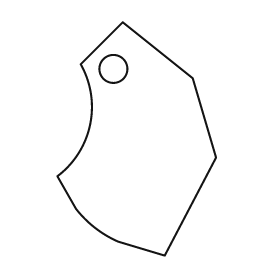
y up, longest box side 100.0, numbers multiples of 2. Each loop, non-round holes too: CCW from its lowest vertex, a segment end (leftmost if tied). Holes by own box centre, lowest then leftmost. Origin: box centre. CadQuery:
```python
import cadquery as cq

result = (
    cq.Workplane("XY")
    .moveTo(12.0, -50.0)
    .lineTo(34.0, -8.0)
    .lineTo(24.0, 26.0)
    .lineTo(-6.0, 50.0)
    .lineTo(-24.0, 32.0)
    .threePointArc((-20.0, 6.0), (-34.0, -16.0))
    .lineTo(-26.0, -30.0)
    .threePointArc((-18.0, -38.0), (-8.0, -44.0))
    .close()
    .moveTo(-10.0, 30.0)
    .circle(6.0)
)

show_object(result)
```